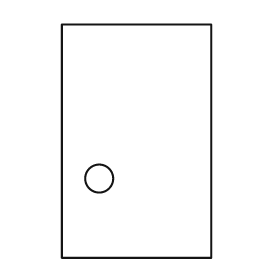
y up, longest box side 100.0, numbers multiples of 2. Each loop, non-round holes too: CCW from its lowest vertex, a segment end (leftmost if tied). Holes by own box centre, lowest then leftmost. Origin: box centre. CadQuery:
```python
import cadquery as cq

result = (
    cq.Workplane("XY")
    .moveTo(-32.0, -50.0)
    .lineTo(32.0, -50.0)
    .lineTo(32.0, 50.0)
    .lineTo(-32.0, 50.0)
    .close()
    .moveTo(-16.0, -16.0)
    .circle(6.0)
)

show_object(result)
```